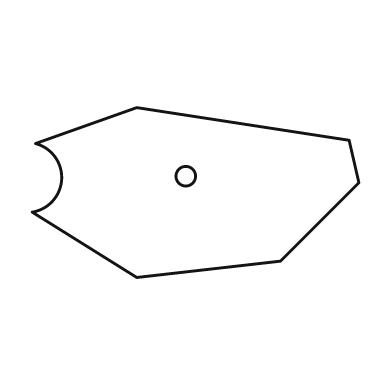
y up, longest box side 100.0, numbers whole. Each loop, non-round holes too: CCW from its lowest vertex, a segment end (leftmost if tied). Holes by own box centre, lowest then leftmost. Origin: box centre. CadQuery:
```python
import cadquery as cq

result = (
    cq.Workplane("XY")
    .moveTo(-18.0, -26.0)
    .lineTo(26.0, -21.0)
    .lineTo(50.0, 3.0)
    .lineTo(47.0, 16.0)
    .lineTo(-18.0, 26.0)
    .lineTo(-49.0, 15.0)
    .threePointArc((-41.0, 4.0), (-50.0, -6.0))
    .close()
    .moveTo(-3.0, 5.0)
    .circle(3.0)
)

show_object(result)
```